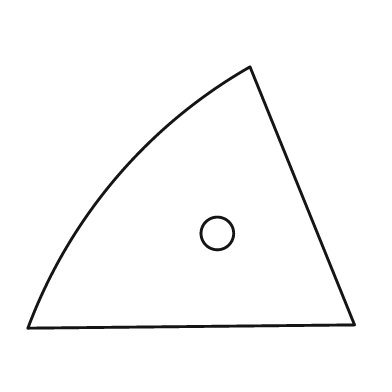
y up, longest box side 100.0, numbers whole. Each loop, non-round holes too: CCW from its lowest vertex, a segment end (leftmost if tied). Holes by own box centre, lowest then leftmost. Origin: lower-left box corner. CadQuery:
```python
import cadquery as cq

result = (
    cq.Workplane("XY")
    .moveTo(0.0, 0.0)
    .lineTo(100.0, 1.0)
    .lineTo(68.0, 80.0)
    .threePointArc((27.0, 46.0), (0.0, 0.0))
    .close()
    .moveTo(58.0, 29.0)
    .circle(5.0)
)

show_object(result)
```